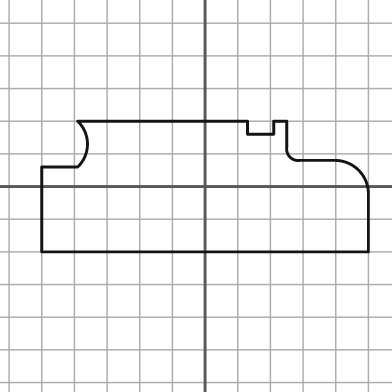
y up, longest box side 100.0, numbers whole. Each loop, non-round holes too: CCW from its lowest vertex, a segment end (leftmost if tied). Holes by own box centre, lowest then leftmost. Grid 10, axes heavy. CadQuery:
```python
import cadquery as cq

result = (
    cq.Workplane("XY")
    .moveTo(-50.0, -20.0)
    .lineTo(50.0, -20.0)
    .lineTo(50.0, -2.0)
    .threePointArc((47.0, 5.0), (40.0, 8.0))
    .lineTo(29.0, 8.0)
    .threePointArc((26.0, 9.0), (25.0, 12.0))
    .lineTo(25.0, 20.0)
    .lineTo(21.0, 20.0)
    .lineTo(21.0, 16.0)
    .lineTo(13.0, 16.0)
    .lineTo(13.0, 20.0)
    .lineTo(-39.0, 20.0)
    .threePointArc((-36.0, 13.0), (-39.0, 6.0))
    .lineTo(-50.0, 6.0)
    .close()
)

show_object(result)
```